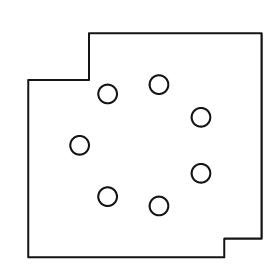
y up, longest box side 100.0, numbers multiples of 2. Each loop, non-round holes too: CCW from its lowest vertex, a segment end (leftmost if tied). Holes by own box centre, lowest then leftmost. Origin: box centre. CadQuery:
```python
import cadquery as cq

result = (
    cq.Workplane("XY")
    .moveTo(-50.0, -48.0)
    .lineTo(34.0, -48.0)
    .lineTo(34.0, -40.0)
    .lineTo(50.0, -40.0)
    .lineTo(50.0, 48.0)
    .lineTo(-24.0, 48.0)
    .lineTo(-24.0, 28.0)
    .lineTo(-50.0, 28.0)
    .close()
    .moveTo(6.0, -26.0)
    .circle(4.0)
    .moveTo(-16.0, -22.0)
    .circle(4.0)
    .moveTo(24.0, -12.0)
    .circle(4.0)
    .moveTo(-28.0, 0.0)
    .circle(4.0)
    .moveTo(24.0, 12.0)
    .circle(4.0)
    .moveTo(-16.0, 22.0)
    .circle(4.0)
    .moveTo(6.0, 26.0)
    .circle(4.0)
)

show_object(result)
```